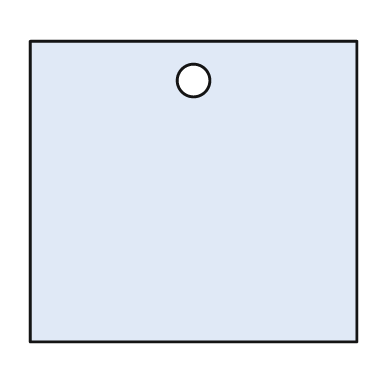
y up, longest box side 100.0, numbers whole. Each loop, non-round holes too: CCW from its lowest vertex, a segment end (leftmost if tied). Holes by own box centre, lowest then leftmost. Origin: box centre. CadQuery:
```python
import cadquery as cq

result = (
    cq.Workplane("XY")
    .moveTo(-50.0, -46.0)
    .lineTo(50.0, -46.0)
    .lineTo(50.0, 46.0)
    .lineTo(-50.0, 46.0)
    .close()
    .moveTo(0.0, 34.0)
    .circle(5.0)
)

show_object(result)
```